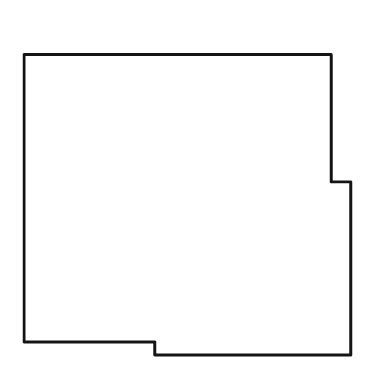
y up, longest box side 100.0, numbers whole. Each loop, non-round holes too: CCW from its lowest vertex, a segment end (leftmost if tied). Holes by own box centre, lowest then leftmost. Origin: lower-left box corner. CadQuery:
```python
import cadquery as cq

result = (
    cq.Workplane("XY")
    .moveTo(40.0, 0.0)
    .lineTo(100.0, 0.0)
    .lineTo(100.0, 53.0)
    .lineTo(94.0, 53.0)
    .lineTo(94.0, 92.0)
    .lineTo(0.0, 92.0)
    .lineTo(0.0, 4.0)
    .lineTo(40.0, 4.0)
    .close()
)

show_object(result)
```